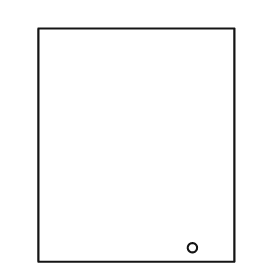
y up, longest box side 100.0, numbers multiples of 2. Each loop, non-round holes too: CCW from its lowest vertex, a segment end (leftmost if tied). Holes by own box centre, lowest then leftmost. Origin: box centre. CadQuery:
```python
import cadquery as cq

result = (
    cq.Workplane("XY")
    .moveTo(-42.0, -50.0)
    .lineTo(42.0, -50.0)
    .lineTo(42.0, 50.0)
    .lineTo(-42.0, 50.0)
    .close()
    .moveTo(24.0, -44.0)
    .circle(2.0)
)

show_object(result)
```